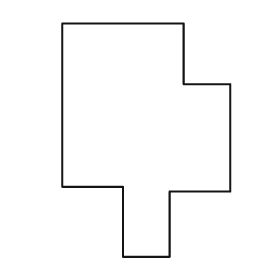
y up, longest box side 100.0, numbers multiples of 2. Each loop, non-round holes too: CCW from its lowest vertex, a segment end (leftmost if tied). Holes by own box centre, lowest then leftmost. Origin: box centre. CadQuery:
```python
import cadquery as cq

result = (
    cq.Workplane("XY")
    .moveTo(-10.0, -50.0)
    .lineTo(10.0, -50.0)
    .lineTo(10.0, -22.0)
    .lineTo(36.0, -22.0)
    .lineTo(36.0, 24.0)
    .lineTo(16.0, 24.0)
    .lineTo(16.0, 50.0)
    .lineTo(-36.0, 50.0)
    .lineTo(-36.0, -20.0)
    .lineTo(-10.0, -20.0)
    .close()
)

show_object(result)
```